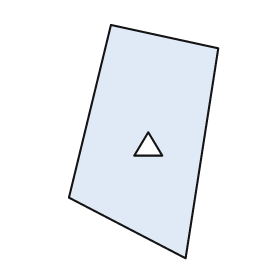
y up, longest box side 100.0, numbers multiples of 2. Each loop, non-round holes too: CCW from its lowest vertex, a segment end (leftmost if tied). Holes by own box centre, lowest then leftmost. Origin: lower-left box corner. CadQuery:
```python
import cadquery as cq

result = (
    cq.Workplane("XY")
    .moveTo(50.0, 0.0)
    .lineTo(64.0, 90.0)
    .lineTo(18.0, 100.0)
    .lineTo(0.0, 26.0)
    .close()
    .moveTo(28.0, 44.0)
    .lineTo(40.0, 44.0)
    .lineTo(34.0, 54.0)
    .close()
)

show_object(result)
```